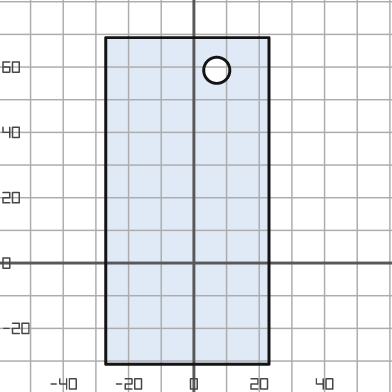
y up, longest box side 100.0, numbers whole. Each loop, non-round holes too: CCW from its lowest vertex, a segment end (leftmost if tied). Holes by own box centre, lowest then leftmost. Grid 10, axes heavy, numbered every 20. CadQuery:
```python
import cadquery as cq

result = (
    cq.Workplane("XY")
    .moveTo(-27.0, -31.0)
    .lineTo(23.0, -31.0)
    .lineTo(23.0, 69.0)
    .lineTo(-27.0, 69.0)
    .close()
    .moveTo(7.0, 59.0)
    .circle(4.0)
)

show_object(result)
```